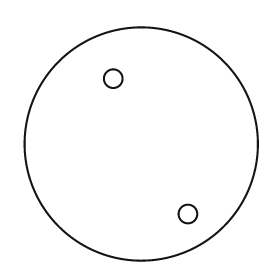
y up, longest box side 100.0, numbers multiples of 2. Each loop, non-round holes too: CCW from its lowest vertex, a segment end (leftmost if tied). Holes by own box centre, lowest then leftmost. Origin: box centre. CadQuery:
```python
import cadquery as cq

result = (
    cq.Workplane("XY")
    .moveTo(0.0, 0.0)
    .circle(50.0)
    .moveTo(20.0, -30.0)
    .circle(4.0)
    .moveTo(-12.0, 28.0)
    .circle(4.0)
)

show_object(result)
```